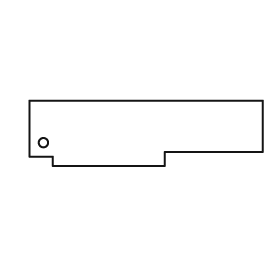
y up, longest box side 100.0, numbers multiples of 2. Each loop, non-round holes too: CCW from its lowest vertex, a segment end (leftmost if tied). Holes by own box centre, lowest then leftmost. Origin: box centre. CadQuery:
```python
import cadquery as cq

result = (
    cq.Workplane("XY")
    .moveTo(-40.0, -14.0)
    .lineTo(8.0, -14.0)
    .lineTo(8.0, -8.0)
    .lineTo(50.0, -8.0)
    .lineTo(50.0, 14.0)
    .lineTo(-50.0, 14.0)
    .lineTo(-50.0, -10.0)
    .lineTo(-40.0, -10.0)
    .close()
    .moveTo(-44.0, -4.0)
    .circle(2.0)
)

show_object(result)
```